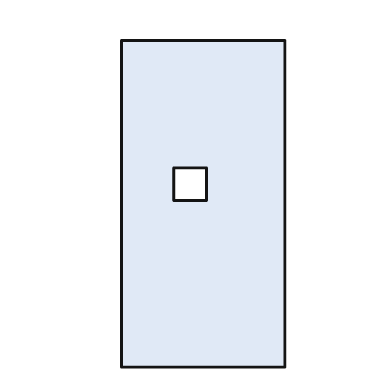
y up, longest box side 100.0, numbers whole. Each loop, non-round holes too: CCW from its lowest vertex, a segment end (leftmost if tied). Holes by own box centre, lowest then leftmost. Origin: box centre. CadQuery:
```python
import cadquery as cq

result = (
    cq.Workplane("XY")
    .moveTo(-25.0, -50.0)
    .lineTo(25.0, -50.0)
    .lineTo(25.0, 50.0)
    .lineTo(-25.0, 50.0)
    .close()
    .moveTo(-9.0, 1.0)
    .lineTo(1.0, 1.0)
    .lineTo(1.0, 11.0)
    .lineTo(-9.0, 11.0)
    .close()
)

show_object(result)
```